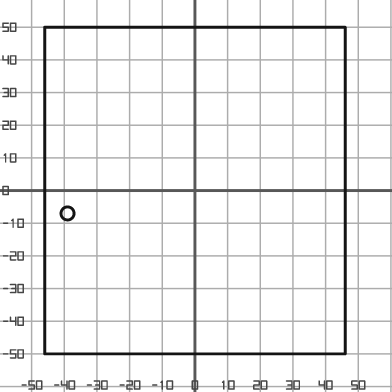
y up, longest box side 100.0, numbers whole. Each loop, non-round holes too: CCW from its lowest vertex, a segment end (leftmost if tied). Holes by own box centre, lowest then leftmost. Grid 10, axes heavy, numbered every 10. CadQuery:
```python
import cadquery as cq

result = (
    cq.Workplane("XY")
    .moveTo(-46.0, -50.0)
    .lineTo(46.0, -50.0)
    .lineTo(46.0, 50.0)
    .lineTo(-46.0, 50.0)
    .close()
    .moveTo(-39.0, -7.0)
    .circle(2.0)
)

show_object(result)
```